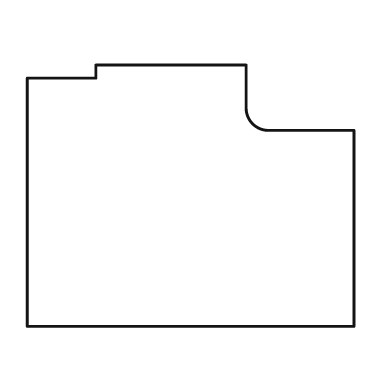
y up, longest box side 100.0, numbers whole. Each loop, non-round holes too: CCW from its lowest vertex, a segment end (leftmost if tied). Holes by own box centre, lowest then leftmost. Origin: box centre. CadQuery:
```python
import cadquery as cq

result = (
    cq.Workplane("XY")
    .moveTo(-50.0, -40.0)
    .lineTo(50.0, -40.0)
    .lineTo(50.0, 20.0)
    .lineTo(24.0, 20.0)
    .threePointArc((19.0, 22.0), (17.0, 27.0))
    .lineTo(17.0, 40.0)
    .lineTo(-29.0, 40.0)
    .lineTo(-29.0, 36.0)
    .lineTo(-50.0, 36.0)
    .close()
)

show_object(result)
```